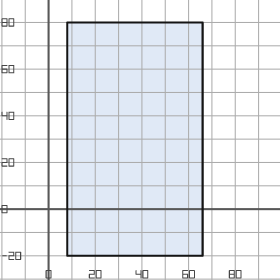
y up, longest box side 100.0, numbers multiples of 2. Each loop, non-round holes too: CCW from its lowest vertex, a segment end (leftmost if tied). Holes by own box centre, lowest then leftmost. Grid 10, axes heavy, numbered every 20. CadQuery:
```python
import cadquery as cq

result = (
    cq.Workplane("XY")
    .moveTo(8.0, -20.0)
    .lineTo(66.0, -20.0)
    .lineTo(66.0, 80.0)
    .lineTo(8.0, 80.0)
    .close()
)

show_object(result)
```